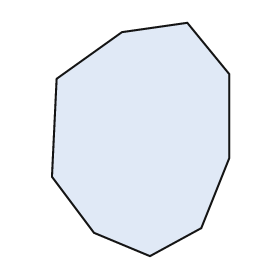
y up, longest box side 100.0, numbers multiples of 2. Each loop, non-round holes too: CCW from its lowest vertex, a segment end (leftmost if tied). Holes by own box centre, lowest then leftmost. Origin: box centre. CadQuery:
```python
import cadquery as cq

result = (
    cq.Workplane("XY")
    .moveTo(4.0, -50.0)
    .lineTo(26.0, -38.0)
    .lineTo(38.0, -8.0)
    .lineTo(38.0, 28.0)
    .lineTo(20.0, 50.0)
    .lineTo(-8.0, 46.0)
    .lineTo(-36.0, 26.0)
    .lineTo(-38.0, -16.0)
    .lineTo(-20.0, -40.0)
    .close()
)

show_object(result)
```